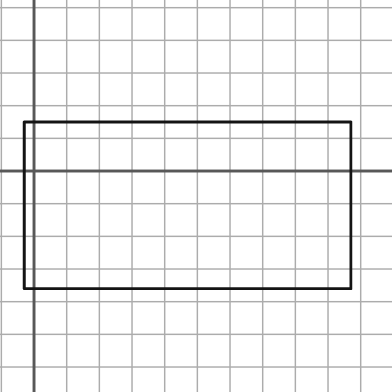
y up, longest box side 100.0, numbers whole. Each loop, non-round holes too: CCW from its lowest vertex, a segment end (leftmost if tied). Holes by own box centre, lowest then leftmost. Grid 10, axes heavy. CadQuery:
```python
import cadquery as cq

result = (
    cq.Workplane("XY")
    .moveTo(-3.0, -36.0)
    .lineTo(97.0, -36.0)
    .lineTo(97.0, 15.0)
    .lineTo(-3.0, 15.0)
    .close()
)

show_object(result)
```